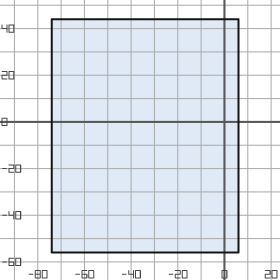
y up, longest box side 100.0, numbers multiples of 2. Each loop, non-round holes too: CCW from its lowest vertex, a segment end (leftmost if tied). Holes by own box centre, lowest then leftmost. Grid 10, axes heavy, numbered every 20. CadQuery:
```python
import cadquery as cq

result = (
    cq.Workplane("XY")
    .moveTo(-74.0, -56.0)
    .lineTo(6.0, -56.0)
    .lineTo(6.0, 44.0)
    .lineTo(-74.0, 44.0)
    .close()
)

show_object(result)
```